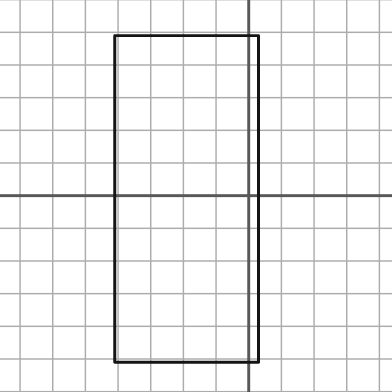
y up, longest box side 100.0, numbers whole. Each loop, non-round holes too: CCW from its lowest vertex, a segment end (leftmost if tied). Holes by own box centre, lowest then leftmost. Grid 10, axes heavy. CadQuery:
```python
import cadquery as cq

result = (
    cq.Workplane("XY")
    .moveTo(-41.0, -51.0)
    .lineTo(3.0, -51.0)
    .lineTo(3.0, 49.0)
    .lineTo(-41.0, 49.0)
    .close()
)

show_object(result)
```